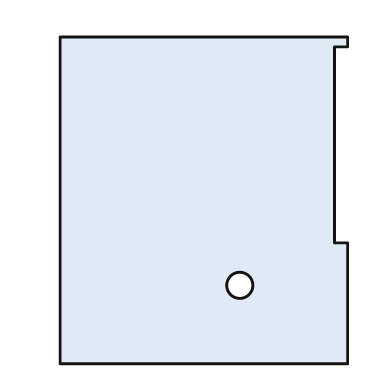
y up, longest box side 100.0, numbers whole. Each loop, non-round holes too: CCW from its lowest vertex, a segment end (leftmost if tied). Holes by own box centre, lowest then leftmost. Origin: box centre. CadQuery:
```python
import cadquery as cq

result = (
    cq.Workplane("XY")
    .moveTo(-44.0, -50.0)
    .lineTo(44.0, -50.0)
    .lineTo(44.0, -13.0)
    .lineTo(40.0, -13.0)
    .lineTo(40.0, 47.0)
    .lineTo(44.0, 47.0)
    .lineTo(44.0, 50.0)
    .lineTo(-44.0, 50.0)
    .close()
    .moveTo(11.0, -26.0)
    .circle(4.0)
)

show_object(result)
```